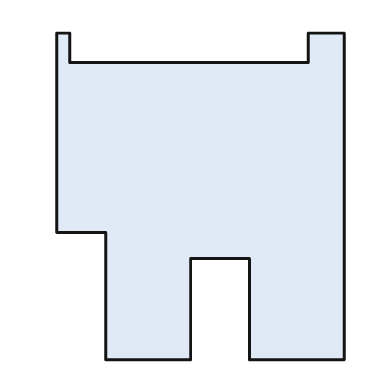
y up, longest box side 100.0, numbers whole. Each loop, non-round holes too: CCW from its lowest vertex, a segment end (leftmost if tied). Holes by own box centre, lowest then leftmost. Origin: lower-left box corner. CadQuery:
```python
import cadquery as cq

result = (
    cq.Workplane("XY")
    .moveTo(15.0, 0.0)
    .lineTo(41.0, 0.0)
    .lineTo(41.0, 31.0)
    .lineTo(59.0, 31.0)
    .lineTo(59.0, 0.0)
    .lineTo(88.0, 0.0)
    .lineTo(88.0, 100.0)
    .lineTo(77.0, 100.0)
    .lineTo(77.0, 91.0)
    .lineTo(4.0, 91.0)
    .lineTo(4.0, 100.0)
    .lineTo(0.0, 100.0)
    .lineTo(0.0, 39.0)
    .lineTo(15.0, 39.0)
    .close()
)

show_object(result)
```